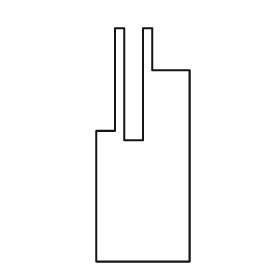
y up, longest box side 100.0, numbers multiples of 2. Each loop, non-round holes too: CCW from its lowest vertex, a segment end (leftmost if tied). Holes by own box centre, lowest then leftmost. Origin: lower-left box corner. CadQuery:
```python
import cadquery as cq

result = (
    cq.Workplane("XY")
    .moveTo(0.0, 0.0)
    .lineTo(40.0, 0.0)
    .lineTo(40.0, 82.0)
    .lineTo(24.0, 82.0)
    .lineTo(24.0, 100.0)
    .lineTo(20.0, 100.0)
    .lineTo(20.0, 52.0)
    .lineTo(12.0, 52.0)
    .lineTo(12.0, 100.0)
    .lineTo(8.0, 100.0)
    .lineTo(8.0, 56.0)
    .lineTo(0.0, 56.0)
    .close()
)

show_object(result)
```